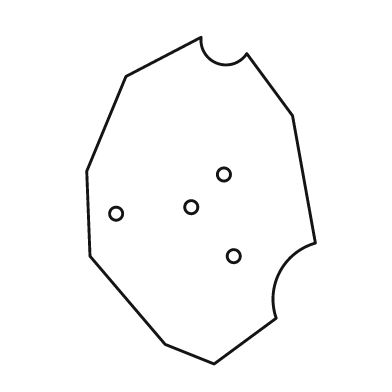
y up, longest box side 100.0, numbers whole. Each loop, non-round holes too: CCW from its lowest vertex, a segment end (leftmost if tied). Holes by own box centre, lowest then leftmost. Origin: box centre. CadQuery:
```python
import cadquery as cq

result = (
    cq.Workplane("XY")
    .moveTo(4.0, -50.0)
    .lineTo(23.0, -36.0)
    .threePointArc((24.0, -22.0), (35.0, -13.0))
    .lineTo(28.0, 26.0)
    .lineTo(14.0, 45.0)
    .threePointArc((5.0, 42.0), (0.0, 50.0))
    .lineTo(-23.0, 38.0)
    .lineTo(-35.0, 9.0)
    .lineTo(-34.0, -17.0)
    .lineTo(-11.0, -44.0)
    .close()
    .moveTo(10.0, -17.0)
    .circle(2.0)
    .moveTo(-26.0, -4.0)
    .circle(2.0)
    .moveTo(-3.0, -2.0)
    .circle(2.0)
    .moveTo(7.0, 8.0)
    .circle(2.0)
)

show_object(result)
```